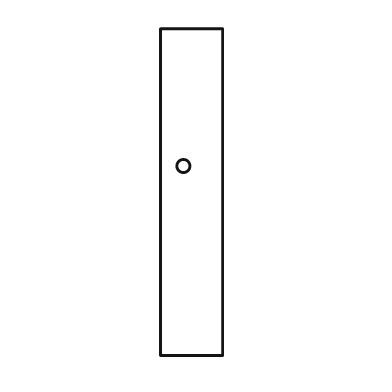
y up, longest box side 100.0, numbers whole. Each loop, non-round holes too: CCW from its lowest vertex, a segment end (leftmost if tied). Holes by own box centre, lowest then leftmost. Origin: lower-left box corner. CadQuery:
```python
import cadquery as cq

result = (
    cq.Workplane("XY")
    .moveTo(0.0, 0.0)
    .lineTo(19.0, 0.0)
    .lineTo(19.0, 100.0)
    .lineTo(0.0, 100.0)
    .close()
    .moveTo(7.0, 58.0)
    .circle(2.0)
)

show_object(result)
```